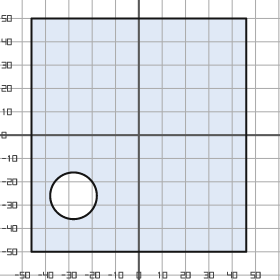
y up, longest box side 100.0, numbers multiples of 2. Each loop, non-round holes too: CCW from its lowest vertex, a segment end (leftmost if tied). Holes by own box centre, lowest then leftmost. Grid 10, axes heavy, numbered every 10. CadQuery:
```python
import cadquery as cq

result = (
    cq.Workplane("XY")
    .moveTo(-46.0, -50.0)
    .lineTo(46.0, -50.0)
    .lineTo(46.0, 50.0)
    .lineTo(-46.0, 50.0)
    .close()
    .moveTo(-28.0, -26.0)
    .circle(10.0)
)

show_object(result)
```